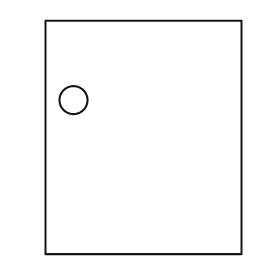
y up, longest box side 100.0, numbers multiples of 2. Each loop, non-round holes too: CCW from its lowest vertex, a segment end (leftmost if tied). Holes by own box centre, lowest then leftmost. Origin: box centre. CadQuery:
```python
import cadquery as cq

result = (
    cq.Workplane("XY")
    .moveTo(-42.0, -50.0)
    .lineTo(42.0, -50.0)
    .lineTo(42.0, 50.0)
    .lineTo(-42.0, 50.0)
    .close()
    .moveTo(-30.0, 16.0)
    .circle(6.0)
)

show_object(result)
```